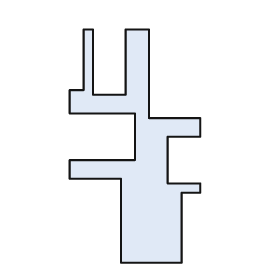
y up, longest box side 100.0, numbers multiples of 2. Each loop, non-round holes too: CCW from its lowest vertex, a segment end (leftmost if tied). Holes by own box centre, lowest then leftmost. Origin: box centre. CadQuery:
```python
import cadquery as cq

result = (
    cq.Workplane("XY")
    .moveTo(-6.0, -50.0)
    .lineTo(20.0, -50.0)
    .lineTo(20.0, -20.0)
    .lineTo(28.0, -20.0)
    .lineTo(28.0, -16.0)
    .lineTo(14.0, -16.0)
    .lineTo(14.0, 4.0)
    .lineTo(28.0, 4.0)
    .lineTo(28.0, 12.0)
    .lineTo(6.0, 12.0)
    .lineTo(6.0, 50.0)
    .lineTo(-4.0, 50.0)
    .lineTo(-4.0, 22.0)
    .lineTo(-18.0, 22.0)
    .lineTo(-18.0, 50.0)
    .lineTo(-22.0, 50.0)
    .lineTo(-22.0, 24.0)
    .lineTo(-28.0, 24.0)
    .lineTo(-28.0, 14.0)
    .lineTo(0.0, 14.0)
    .lineTo(0.0, -6.0)
    .lineTo(-28.0, -6.0)
    .lineTo(-28.0, -14.0)
    .lineTo(-6.0, -14.0)
    .close()
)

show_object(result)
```